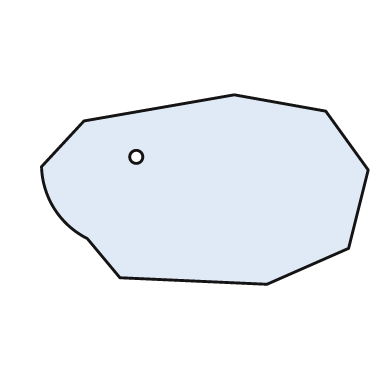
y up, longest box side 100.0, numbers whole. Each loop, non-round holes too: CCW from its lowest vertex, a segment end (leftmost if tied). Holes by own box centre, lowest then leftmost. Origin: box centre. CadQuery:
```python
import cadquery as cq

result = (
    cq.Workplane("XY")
    .moveTo(19.0, -29.0)
    .lineTo(44.0, -18.0)
    .lineTo(50.0, 6.0)
    .lineTo(37.0, 24.0)
    .lineTo(9.0, 29.0)
    .lineTo(-37.0, 21.0)
    .lineTo(-50.0, 7.0)
    .threePointArc((-46.0, -6.0), (-36.0, -15.0))
    .lineTo(-26.0, -27.0)
    .close()
    .moveTo(-21.0, 10.0)
    .circle(2.0)
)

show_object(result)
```